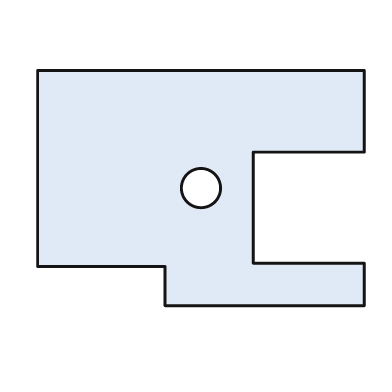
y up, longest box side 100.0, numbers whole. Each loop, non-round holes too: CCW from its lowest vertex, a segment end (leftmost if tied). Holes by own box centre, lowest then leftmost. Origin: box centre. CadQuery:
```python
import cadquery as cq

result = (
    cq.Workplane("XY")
    .moveTo(-11.0, -36.0)
    .lineTo(50.0, -36.0)
    .lineTo(50.0, -23.0)
    .lineTo(16.0, -23.0)
    .lineTo(16.0, 11.0)
    .lineTo(50.0, 11.0)
    .lineTo(50.0, 36.0)
    .lineTo(-50.0, 36.0)
    .lineTo(-50.0, -24.0)
    .lineTo(-11.0, -24.0)
    .close()
    .moveTo(0.0, 0.0)
    .circle(6.0)
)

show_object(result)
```